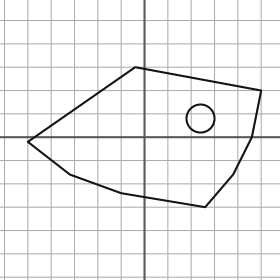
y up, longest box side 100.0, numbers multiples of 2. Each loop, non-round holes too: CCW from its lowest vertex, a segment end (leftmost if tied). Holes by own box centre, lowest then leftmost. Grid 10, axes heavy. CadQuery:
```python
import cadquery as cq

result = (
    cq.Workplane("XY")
    .moveTo(26.0, -30.0)
    .lineTo(38.0, -16.0)
    .lineTo(46.0, 0.0)
    .lineTo(50.0, 20.0)
    .lineTo(-4.0, 30.0)
    .lineTo(-50.0, -2.0)
    .lineTo(-32.0, -16.0)
    .lineTo(-10.0, -24.0)
    .close()
    .moveTo(24.0, 8.0)
    .circle(6.0)
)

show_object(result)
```